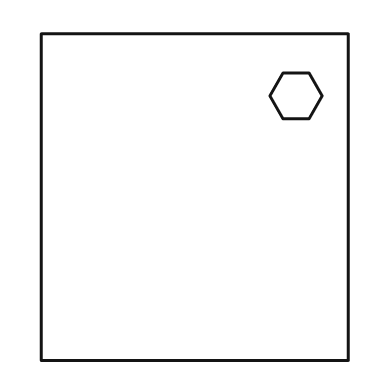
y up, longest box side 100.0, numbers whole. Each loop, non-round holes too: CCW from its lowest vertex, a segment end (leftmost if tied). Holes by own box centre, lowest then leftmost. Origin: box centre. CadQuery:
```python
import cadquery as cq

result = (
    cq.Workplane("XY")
    .moveTo(-47.0, -50.0)
    .lineTo(47.0, -50.0)
    .lineTo(47.0, 50.0)
    .lineTo(-47.0, 50.0)
    .close()
    .moveTo(27.0, 24.0)
    .lineTo(35.0, 24.0)
    .lineTo(39.0, 31.0)
    .lineTo(35.0, 38.0)
    .lineTo(27.0, 38.0)
    .lineTo(23.0, 31.0)
    .close()
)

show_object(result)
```